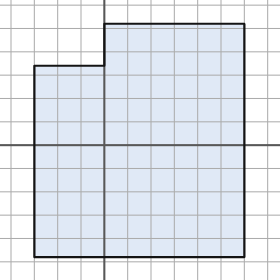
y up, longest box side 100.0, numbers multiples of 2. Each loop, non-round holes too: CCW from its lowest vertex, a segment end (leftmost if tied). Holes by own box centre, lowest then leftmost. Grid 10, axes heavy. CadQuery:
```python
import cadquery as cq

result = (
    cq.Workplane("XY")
    .moveTo(-30.0, -48.0)
    .lineTo(60.0, -48.0)
    .lineTo(60.0, 52.0)
    .lineTo(0.0, 52.0)
    .lineTo(0.0, 34.0)
    .lineTo(-30.0, 34.0)
    .close()
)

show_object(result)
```